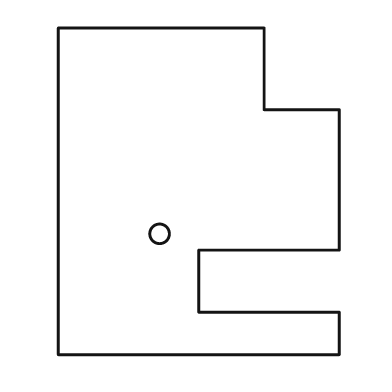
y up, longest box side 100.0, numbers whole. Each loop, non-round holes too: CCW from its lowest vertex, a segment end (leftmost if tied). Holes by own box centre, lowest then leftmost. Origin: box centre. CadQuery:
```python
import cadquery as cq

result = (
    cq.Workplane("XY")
    .moveTo(-43.0, -50.0)
    .lineTo(43.0, -50.0)
    .lineTo(43.0, -37.0)
    .lineTo(0.0, -37.0)
    .lineTo(0.0, -18.0)
    .lineTo(43.0, -18.0)
    .lineTo(43.0, 25.0)
    .lineTo(20.0, 25.0)
    .lineTo(20.0, 50.0)
    .lineTo(-43.0, 50.0)
    .close()
    .moveTo(-12.0, -13.0)
    .circle(3.0)
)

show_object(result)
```